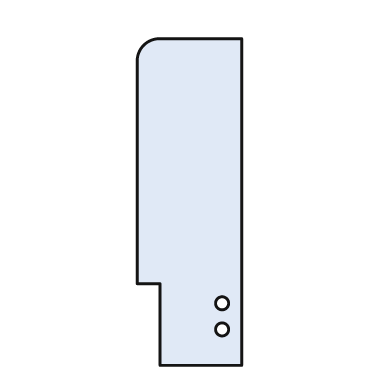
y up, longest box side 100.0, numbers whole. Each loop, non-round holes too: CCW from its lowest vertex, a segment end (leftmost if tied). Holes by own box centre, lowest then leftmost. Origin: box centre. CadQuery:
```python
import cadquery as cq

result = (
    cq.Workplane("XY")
    .moveTo(-9.0, -50.0)
    .lineTo(16.0, -50.0)
    .lineTo(16.0, 50.0)
    .lineTo(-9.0, 50.0)
    .threePointArc((-14.0, 48.0), (-16.0, 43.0))
    .lineTo(-16.0, -25.0)
    .lineTo(-9.0, -25.0)
    .close()
    .moveTo(10.0, -39.0)
    .circle(2.0)
    .moveTo(10.0, -31.0)
    .circle(2.0)
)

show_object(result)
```